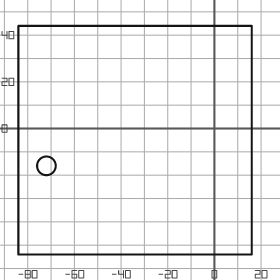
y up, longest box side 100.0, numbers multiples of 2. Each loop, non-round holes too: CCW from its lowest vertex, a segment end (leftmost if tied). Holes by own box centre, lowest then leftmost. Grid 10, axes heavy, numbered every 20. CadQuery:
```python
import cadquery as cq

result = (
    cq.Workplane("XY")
    .moveTo(-84.0, -54.0)
    .lineTo(16.0, -54.0)
    .lineTo(16.0, 44.0)
    .lineTo(-84.0, 44.0)
    .close()
    .moveTo(-72.0, -16.0)
    .circle(4.0)
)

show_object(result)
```